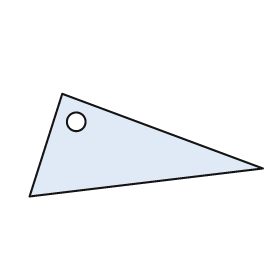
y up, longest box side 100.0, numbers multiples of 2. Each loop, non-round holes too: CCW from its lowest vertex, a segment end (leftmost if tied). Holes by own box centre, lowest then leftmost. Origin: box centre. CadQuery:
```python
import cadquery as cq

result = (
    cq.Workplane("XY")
    .moveTo(-50.0, -22.0)
    .lineTo(50.0, -10.0)
    .lineTo(-36.0, 22.0)
    .close()
    .moveTo(-30.0, 10.0)
    .circle(4.0)
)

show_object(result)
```